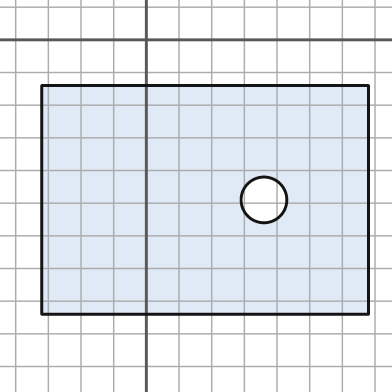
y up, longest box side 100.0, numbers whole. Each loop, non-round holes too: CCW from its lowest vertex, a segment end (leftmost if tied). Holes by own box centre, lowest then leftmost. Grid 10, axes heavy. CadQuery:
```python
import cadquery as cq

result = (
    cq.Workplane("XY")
    .moveTo(-32.0, -84.0)
    .lineTo(68.0, -84.0)
    .lineTo(68.0, -14.0)
    .lineTo(-32.0, -14.0)
    .close()
    .moveTo(36.0, -49.0)
    .circle(7.0)
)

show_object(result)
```